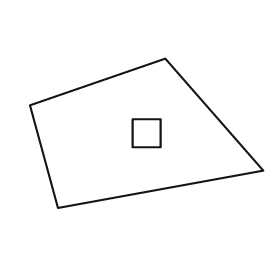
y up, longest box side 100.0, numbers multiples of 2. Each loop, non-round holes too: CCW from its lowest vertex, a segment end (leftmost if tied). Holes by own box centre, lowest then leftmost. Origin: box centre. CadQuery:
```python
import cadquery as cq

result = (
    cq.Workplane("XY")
    .moveTo(-38.0, -32.0)
    .lineTo(50.0, -16.0)
    .lineTo(8.0, 32.0)
    .lineTo(-50.0, 12.0)
    .close()
    .moveTo(-6.0, -6.0)
    .lineTo(6.0, -6.0)
    .lineTo(6.0, 6.0)
    .lineTo(-6.0, 6.0)
    .close()
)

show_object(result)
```